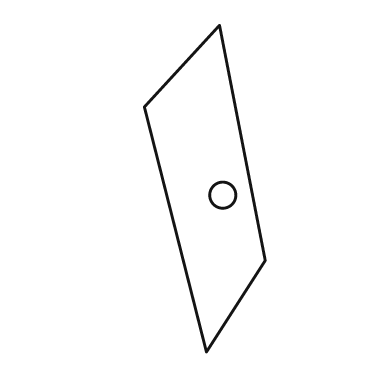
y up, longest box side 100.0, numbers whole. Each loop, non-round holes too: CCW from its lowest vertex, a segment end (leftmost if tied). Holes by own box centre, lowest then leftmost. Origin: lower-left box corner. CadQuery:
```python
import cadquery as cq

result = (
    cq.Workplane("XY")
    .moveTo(19.0, 0.0)
    .lineTo(37.0, 28.0)
    .lineTo(23.0, 100.0)
    .lineTo(0.0, 75.0)
    .close()
    .moveTo(24.0, 48.0)
    .circle(4.0)
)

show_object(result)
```